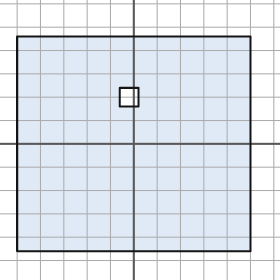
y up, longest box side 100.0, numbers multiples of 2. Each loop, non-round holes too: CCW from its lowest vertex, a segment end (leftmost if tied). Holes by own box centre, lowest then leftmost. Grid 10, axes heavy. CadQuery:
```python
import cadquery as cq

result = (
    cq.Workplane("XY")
    .moveTo(-50.0, -46.0)
    .lineTo(50.0, -46.0)
    .lineTo(50.0, 46.0)
    .lineTo(-50.0, 46.0)
    .close()
    .moveTo(-6.0, 16.0)
    .lineTo(2.0, 16.0)
    .lineTo(2.0, 24.0)
    .lineTo(-6.0, 24.0)
    .close()
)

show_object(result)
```